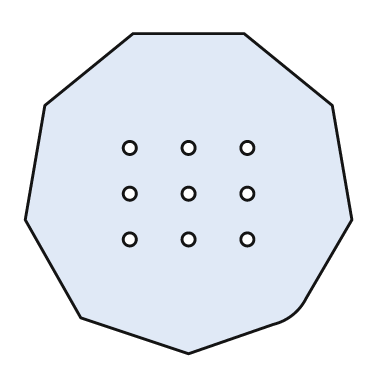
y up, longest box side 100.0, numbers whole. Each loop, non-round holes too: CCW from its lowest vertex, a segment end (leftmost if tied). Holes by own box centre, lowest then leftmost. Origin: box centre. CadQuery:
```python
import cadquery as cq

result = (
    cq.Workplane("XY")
    .moveTo(0.0, -49.0)
    .lineTo(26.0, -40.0)
    .threePointArc((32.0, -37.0), (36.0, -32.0))
    .lineTo(50.0, -8.0)
    .lineTo(44.0, 27.0)
    .lineTo(17.0, 49.0)
    .lineTo(-17.0, 49.0)
    .lineTo(-44.0, 27.0)
    .lineTo(-50.0, -8.0)
    .lineTo(-33.0, -38.0)
    .close()
    .moveTo(-18.0, -14.0)
    .circle(2.0)
    .moveTo(0.0, -14.0)
    .circle(2.0)
    .moveTo(18.0, -14.0)
    .circle(2.0)
    .moveTo(-18.0, 0.0)
    .circle(2.0)
    .moveTo(0.0, 0.0)
    .circle(2.0)
    .moveTo(18.0, 0.0)
    .circle(2.0)
    .moveTo(-18.0, 14.0)
    .circle(2.0)
    .moveTo(0.0, 14.0)
    .circle(2.0)
    .moveTo(18.0, 14.0)
    .circle(2.0)
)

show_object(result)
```